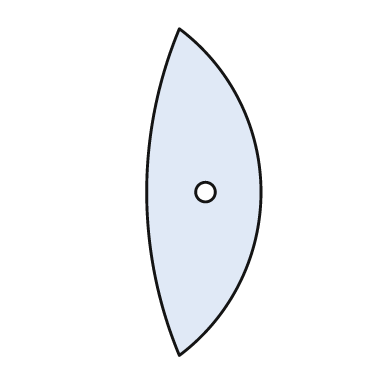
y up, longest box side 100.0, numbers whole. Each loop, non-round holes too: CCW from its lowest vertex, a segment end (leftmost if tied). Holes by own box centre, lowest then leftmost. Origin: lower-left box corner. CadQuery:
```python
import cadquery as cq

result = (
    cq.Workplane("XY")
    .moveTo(10.0, 0.0)
    .threePointArc((35.0, 50.0), (10.0, 100.0))
    .threePointArc((0.0, 50.0), (10.0, 0.0))
    .close()
    .moveTo(18.0, 50.0)
    .circle(3.0)
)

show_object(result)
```